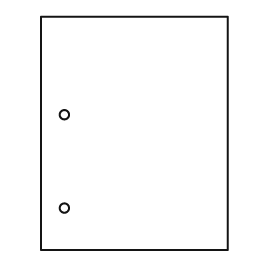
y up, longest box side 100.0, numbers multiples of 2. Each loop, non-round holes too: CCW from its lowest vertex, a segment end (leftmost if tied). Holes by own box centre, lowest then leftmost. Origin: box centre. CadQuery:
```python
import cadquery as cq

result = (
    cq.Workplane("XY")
    .moveTo(-40.0, -50.0)
    .lineTo(40.0, -50.0)
    .lineTo(40.0, 50.0)
    .lineTo(-40.0, 50.0)
    .close()
    .moveTo(-30.0, -32.0)
    .circle(2.0)
    .moveTo(-30.0, 8.0)
    .circle(2.0)
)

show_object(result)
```